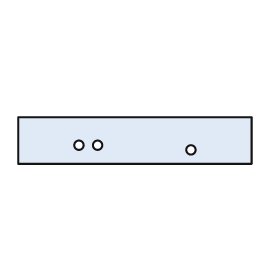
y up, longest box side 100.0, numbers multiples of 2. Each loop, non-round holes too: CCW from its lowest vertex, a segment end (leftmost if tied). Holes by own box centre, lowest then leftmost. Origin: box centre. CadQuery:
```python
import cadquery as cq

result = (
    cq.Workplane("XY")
    .moveTo(-50.0, -10.0)
    .lineTo(50.0, -10.0)
    .lineTo(50.0, 10.0)
    .lineTo(-50.0, 10.0)
    .close()
    .moveTo(24.0, -4.0)
    .circle(2.0)
    .moveTo(-24.0, -2.0)
    .circle(2.0)
    .moveTo(-16.0, -2.0)
    .circle(2.0)
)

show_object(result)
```